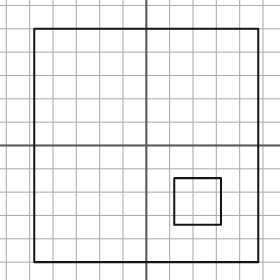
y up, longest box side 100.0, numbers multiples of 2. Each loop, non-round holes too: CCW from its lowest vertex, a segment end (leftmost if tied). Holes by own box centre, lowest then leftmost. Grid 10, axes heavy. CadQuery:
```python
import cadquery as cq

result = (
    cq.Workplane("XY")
    .moveTo(-48.0, -50.0)
    .lineTo(48.0, -50.0)
    .lineTo(48.0, 50.0)
    .lineTo(-48.0, 50.0)
    .close()
    .moveTo(12.0, -34.0)
    .lineTo(32.0, -34.0)
    .lineTo(32.0, -14.0)
    .lineTo(12.0, -14.0)
    .close()
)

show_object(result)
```